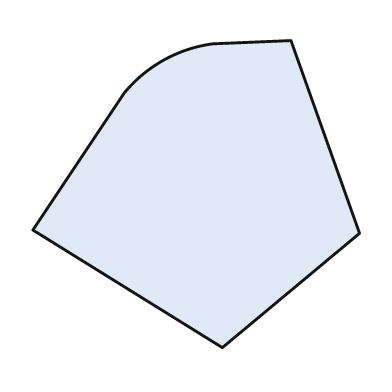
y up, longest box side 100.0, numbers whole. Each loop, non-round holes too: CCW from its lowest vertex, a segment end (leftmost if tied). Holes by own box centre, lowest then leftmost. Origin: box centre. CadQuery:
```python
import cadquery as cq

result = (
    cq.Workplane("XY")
    .moveTo(8.0, -47.0)
    .lineTo(50.0, -12.0)
    .lineTo(29.0, 47.0)
    .lineTo(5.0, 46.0)
    .threePointArc((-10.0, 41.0), (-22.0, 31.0))
    .lineTo(-50.0, -11.0)
    .close()
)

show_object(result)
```